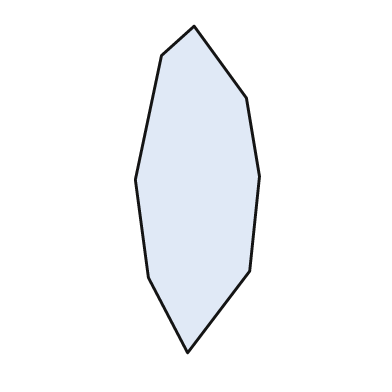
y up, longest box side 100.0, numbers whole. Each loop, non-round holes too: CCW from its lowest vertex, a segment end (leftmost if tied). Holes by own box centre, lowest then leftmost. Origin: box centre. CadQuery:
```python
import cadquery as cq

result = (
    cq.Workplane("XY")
    .moveTo(-3.0, -50.0)
    .lineTo(16.0, -25.0)
    .lineTo(19.0, 4.0)
    .lineTo(15.0, 28.0)
    .lineTo(-1.0, 50.0)
    .lineTo(-11.0, 41.0)
    .lineTo(-19.0, 3.0)
    .lineTo(-15.0, -27.0)
    .close()
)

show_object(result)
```